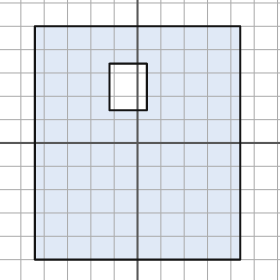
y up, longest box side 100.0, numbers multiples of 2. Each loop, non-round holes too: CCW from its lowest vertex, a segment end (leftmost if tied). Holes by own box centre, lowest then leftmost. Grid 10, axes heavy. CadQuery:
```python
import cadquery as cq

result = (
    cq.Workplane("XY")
    .moveTo(-44.0, -50.0)
    .lineTo(44.0, -50.0)
    .lineTo(44.0, 50.0)
    .lineTo(-44.0, 50.0)
    .close()
    .moveTo(-12.0, 14.0)
    .lineTo(4.0, 14.0)
    .lineTo(4.0, 34.0)
    .lineTo(-12.0, 34.0)
    .close()
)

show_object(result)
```